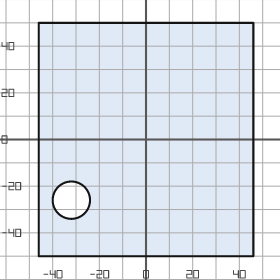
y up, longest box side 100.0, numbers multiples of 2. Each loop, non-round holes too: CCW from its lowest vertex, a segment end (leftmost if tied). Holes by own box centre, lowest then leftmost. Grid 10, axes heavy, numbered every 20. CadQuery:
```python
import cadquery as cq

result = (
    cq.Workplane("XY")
    .moveTo(-46.0, -50.0)
    .lineTo(46.0, -50.0)
    .lineTo(46.0, 50.0)
    .lineTo(-46.0, 50.0)
    .close()
    .moveTo(-32.0, -26.0)
    .circle(8.0)
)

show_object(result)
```